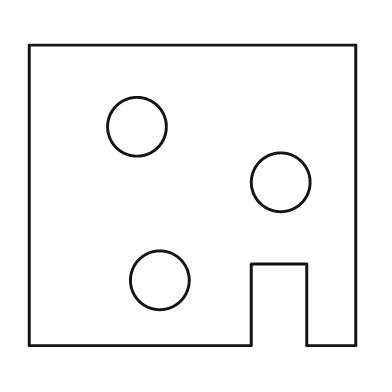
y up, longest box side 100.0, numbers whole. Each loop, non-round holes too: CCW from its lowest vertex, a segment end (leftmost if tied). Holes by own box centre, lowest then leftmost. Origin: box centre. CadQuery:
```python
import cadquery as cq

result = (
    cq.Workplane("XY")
    .moveTo(-50.0, -46.0)
    .lineTo(18.0, -46.0)
    .lineTo(18.0, -21.0)
    .lineTo(35.0, -21.0)
    .lineTo(35.0, -46.0)
    .lineTo(50.0, -46.0)
    .lineTo(50.0, 46.0)
    .lineTo(-50.0, 46.0)
    .close()
    .moveTo(-10.0, -26.0)
    .circle(9.0)
    .moveTo(27.0, 4.0)
    .circle(9.0)
    .moveTo(-17.0, 21.0)
    .circle(9.0)
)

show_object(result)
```